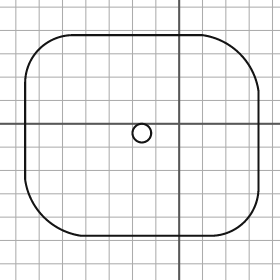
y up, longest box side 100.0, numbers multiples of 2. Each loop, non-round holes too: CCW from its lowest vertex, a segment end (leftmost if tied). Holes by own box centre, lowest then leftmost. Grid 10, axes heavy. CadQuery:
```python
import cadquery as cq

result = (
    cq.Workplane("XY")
    .moveTo(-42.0, -48.0)
    .lineTo(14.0, -48.0)
    .threePointArc((28.0, -42.0), (34.0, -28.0))
    .lineTo(34.0, 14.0)
    .threePointArc((26.0, 30.0), (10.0, 38.0))
    .lineTo(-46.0, 38.0)
    .threePointArc((-60.0, 32.0), (-66.0, 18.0))
    .lineTo(-66.0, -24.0)
    .threePointArc((-58.0, -40.0), (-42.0, -48.0))
    .close()
    .moveTo(-16.0, -4.0)
    .circle(4.0)
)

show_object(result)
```